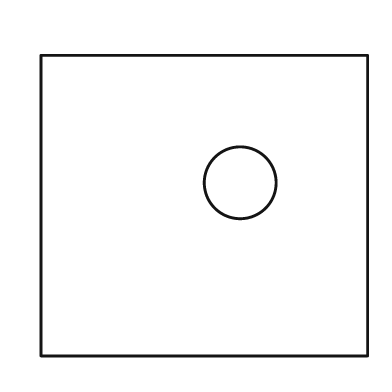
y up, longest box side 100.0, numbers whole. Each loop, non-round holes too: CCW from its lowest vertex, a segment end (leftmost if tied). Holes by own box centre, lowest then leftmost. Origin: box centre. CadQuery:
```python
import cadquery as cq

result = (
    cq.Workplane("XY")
    .moveTo(-50.0, -46.0)
    .lineTo(50.0, -46.0)
    .lineTo(50.0, 46.0)
    .lineTo(-50.0, 46.0)
    .close()
    .moveTo(11.0, 7.0)
    .circle(11.0)
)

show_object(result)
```